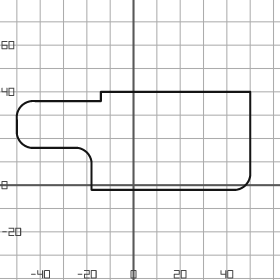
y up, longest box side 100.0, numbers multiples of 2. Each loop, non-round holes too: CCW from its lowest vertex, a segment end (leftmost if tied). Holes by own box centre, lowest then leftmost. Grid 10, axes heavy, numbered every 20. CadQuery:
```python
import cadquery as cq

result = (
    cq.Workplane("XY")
    .moveTo(-18.0, -2.0)
    .lineTo(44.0, -2.0)
    .threePointArc((48.0, 0.0), (50.0, 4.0))
    .lineTo(50.0, 40.0)
    .lineTo(-14.0, 40.0)
    .lineTo(-14.0, 36.0)
    .lineTo(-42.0, 36.0)
    .threePointArc((-48.0, 34.0), (-50.0, 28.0))
    .lineTo(-50.0, 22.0)
    .threePointArc((-48.0, 18.0), (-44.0, 16.0))
    .lineTo(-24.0, 16.0)
    .threePointArc((-20.0, 14.0), (-18.0, 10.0))
    .close()
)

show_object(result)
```